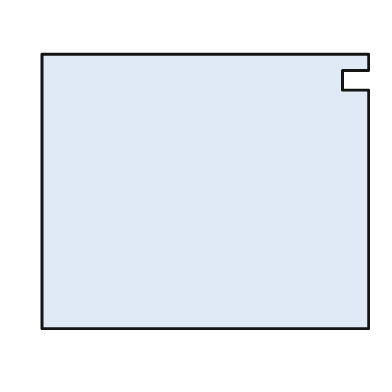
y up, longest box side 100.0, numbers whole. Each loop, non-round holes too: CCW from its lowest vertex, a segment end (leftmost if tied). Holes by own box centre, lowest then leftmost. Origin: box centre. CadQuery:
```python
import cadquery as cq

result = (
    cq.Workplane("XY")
    .moveTo(-50.0, -42.0)
    .lineTo(50.0, -42.0)
    .lineTo(50.0, 31.0)
    .lineTo(42.0, 31.0)
    .lineTo(42.0, 37.0)
    .lineTo(50.0, 37.0)
    .lineTo(50.0, 42.0)
    .lineTo(-50.0, 42.0)
    .close()
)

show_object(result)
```